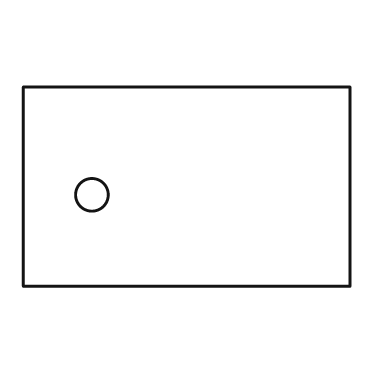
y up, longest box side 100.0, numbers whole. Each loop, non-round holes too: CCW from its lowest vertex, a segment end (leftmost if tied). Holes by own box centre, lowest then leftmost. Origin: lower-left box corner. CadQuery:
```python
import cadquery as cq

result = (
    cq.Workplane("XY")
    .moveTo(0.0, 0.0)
    .lineTo(100.0, 0.0)
    .lineTo(100.0, 61.0)
    .lineTo(0.0, 61.0)
    .close()
    .moveTo(21.0, 28.0)
    .circle(5.0)
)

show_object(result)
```